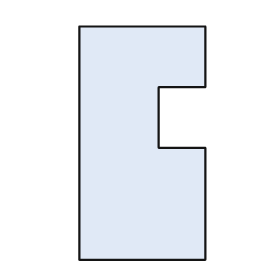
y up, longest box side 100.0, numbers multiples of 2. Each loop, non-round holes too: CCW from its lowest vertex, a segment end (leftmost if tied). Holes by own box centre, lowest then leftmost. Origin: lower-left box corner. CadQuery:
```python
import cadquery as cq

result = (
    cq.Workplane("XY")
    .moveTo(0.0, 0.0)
    .lineTo(54.0, 0.0)
    .lineTo(54.0, 48.0)
    .lineTo(34.0, 48.0)
    .lineTo(34.0, 74.0)
    .lineTo(54.0, 74.0)
    .lineTo(54.0, 100.0)
    .lineTo(0.0, 100.0)
    .close()
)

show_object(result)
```